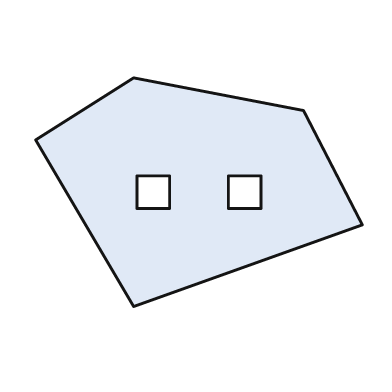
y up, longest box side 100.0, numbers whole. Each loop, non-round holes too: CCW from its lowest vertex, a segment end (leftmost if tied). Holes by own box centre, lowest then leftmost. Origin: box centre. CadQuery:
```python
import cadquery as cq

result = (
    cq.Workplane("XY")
    .moveTo(-20.0, -35.0)
    .lineTo(50.0, -10.0)
    .lineTo(32.0, 25.0)
    .lineTo(-20.0, 35.0)
    .lineTo(-50.0, 16.0)
    .close()
    .moveTo(-19.0, -5.0)
    .lineTo(-9.0, -5.0)
    .lineTo(-9.0, 5.0)
    .lineTo(-19.0, 5.0)
    .close()
    .moveTo(9.0, -5.0)
    .lineTo(19.0, -5.0)
    .lineTo(19.0, 5.0)
    .lineTo(9.0, 5.0)
    .close()
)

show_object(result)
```